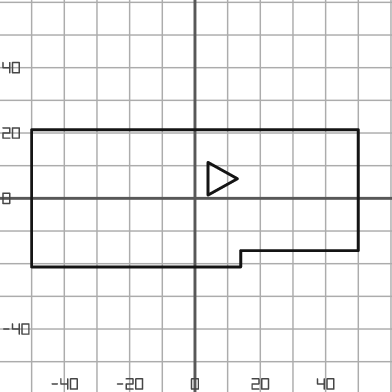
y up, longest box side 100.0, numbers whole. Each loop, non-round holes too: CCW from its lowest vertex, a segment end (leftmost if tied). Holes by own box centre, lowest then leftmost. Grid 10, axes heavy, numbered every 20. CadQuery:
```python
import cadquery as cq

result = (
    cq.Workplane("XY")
    .moveTo(-50.0, -21.0)
    .lineTo(14.0, -21.0)
    .lineTo(14.0, -16.0)
    .lineTo(50.0, -16.0)
    .lineTo(50.0, 21.0)
    .lineTo(-50.0, 21.0)
    .close()
    .moveTo(4.0, 1.0)
    .lineTo(13.0, 6.0)
    .lineTo(4.0, 11.0)
    .close()
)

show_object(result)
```